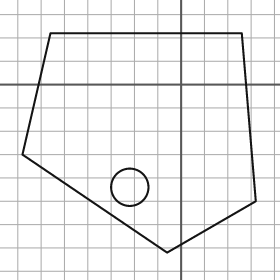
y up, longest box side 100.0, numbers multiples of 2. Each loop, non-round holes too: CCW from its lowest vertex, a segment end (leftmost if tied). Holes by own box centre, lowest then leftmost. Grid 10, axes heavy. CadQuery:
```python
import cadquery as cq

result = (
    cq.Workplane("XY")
    .moveTo(-6.0, -72.0)
    .lineTo(32.0, -50.0)
    .lineTo(26.0, 22.0)
    .lineTo(-56.0, 22.0)
    .lineTo(-68.0, -30.0)
    .close()
    .moveTo(-22.0, -44.0)
    .circle(8.0)
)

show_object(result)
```